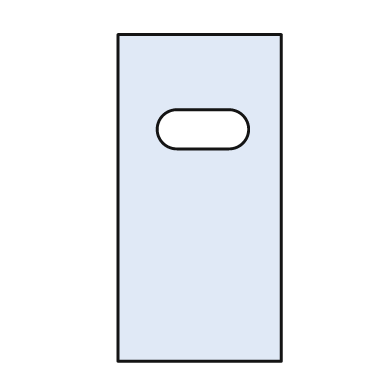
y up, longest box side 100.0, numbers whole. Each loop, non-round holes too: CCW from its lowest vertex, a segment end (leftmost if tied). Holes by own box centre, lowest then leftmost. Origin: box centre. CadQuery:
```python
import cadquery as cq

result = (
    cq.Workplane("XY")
    .moveTo(-25.0, -50.0)
    .lineTo(25.0, -50.0)
    .lineTo(25.0, 50.0)
    .lineTo(-25.0, 50.0)
    .close()
    .moveTo(-7.0, 15.0)
    .lineTo(9.0, 15.0)
    .threePointArc((15.0, 21.0), (9.0, 27.0))
    .lineTo(-7.0, 27.0)
    .threePointArc((-13.0, 21.0), (-7.0, 15.0))
    .close()
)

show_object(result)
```